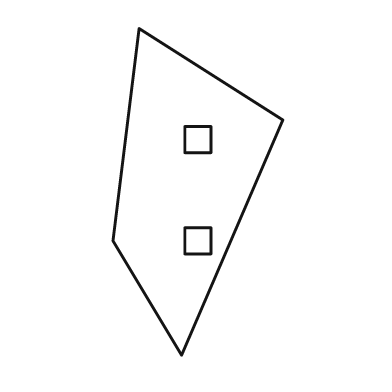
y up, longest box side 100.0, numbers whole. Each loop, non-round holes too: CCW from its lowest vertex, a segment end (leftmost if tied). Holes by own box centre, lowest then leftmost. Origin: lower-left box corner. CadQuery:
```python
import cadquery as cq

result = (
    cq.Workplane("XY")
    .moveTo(21.0, 0.0)
    .lineTo(52.0, 72.0)
    .lineTo(8.0, 100.0)
    .lineTo(0.0, 35.0)
    .close()
    .moveTo(22.0, 31.0)
    .lineTo(30.0, 31.0)
    .lineTo(30.0, 39.0)
    .lineTo(22.0, 39.0)
    .close()
    .moveTo(22.0, 62.0)
    .lineTo(30.0, 62.0)
    .lineTo(30.0, 70.0)
    .lineTo(22.0, 70.0)
    .close()
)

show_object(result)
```